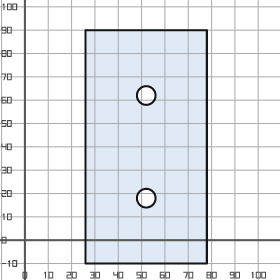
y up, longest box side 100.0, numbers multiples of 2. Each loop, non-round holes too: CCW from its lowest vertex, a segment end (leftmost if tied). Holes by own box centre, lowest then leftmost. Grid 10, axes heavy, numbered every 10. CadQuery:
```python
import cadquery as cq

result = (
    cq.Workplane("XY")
    .moveTo(26.0, -10.0)
    .lineTo(78.0, -10.0)
    .lineTo(78.0, 90.0)
    .lineTo(26.0, 90.0)
    .close()
    .moveTo(52.0, 18.0)
    .circle(4.0)
    .moveTo(52.0, 62.0)
    .circle(4.0)
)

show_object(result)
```